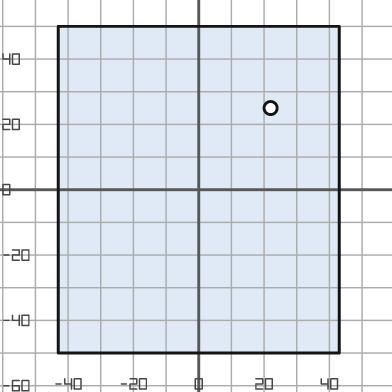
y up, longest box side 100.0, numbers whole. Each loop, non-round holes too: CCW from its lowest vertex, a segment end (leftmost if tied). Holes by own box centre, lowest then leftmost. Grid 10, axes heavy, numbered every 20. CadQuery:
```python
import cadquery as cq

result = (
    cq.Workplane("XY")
    .moveTo(-43.0, -50.0)
    .lineTo(43.0, -50.0)
    .lineTo(43.0, 50.0)
    .lineTo(-43.0, 50.0)
    .close()
    .moveTo(22.0, 25.0)
    .circle(2.0)
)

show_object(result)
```